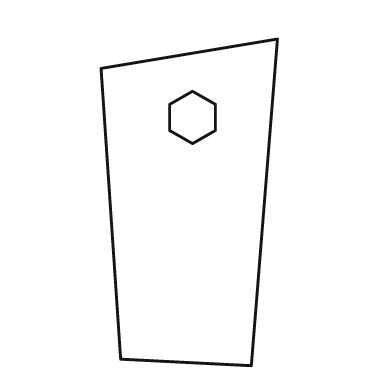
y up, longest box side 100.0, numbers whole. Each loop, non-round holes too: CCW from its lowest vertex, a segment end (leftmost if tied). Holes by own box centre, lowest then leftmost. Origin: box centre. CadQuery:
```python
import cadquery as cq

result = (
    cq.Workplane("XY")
    .moveTo(19.0, -50.0)
    .lineTo(27.0, 50.0)
    .lineTo(-27.0, 41.0)
    .lineTo(-21.0, -48.0)
    .close()
    .moveTo(1.0, 18.0)
    .lineTo(8.0, 22.0)
    .lineTo(8.0, 30.0)
    .lineTo(1.0, 34.0)
    .lineTo(-6.0, 30.0)
    .lineTo(-6.0, 22.0)
    .close()
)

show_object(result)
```